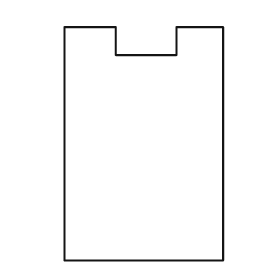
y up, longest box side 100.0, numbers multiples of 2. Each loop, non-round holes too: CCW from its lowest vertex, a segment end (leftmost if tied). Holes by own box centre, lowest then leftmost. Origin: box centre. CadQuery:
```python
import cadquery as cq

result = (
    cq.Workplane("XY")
    .moveTo(-34.0, -50.0)
    .lineTo(34.0, -50.0)
    .lineTo(34.0, 50.0)
    .lineTo(14.0, 50.0)
    .lineTo(14.0, 38.0)
    .lineTo(-12.0, 38.0)
    .lineTo(-12.0, 50.0)
    .lineTo(-34.0, 50.0)
    .close()
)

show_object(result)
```